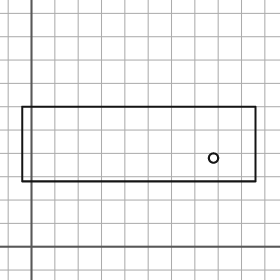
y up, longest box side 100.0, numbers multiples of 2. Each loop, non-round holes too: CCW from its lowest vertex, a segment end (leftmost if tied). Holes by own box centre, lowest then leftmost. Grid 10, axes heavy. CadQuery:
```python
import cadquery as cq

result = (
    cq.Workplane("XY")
    .moveTo(-4.0, 28.0)
    .lineTo(96.0, 28.0)
    .lineTo(96.0, 60.0)
    .lineTo(-4.0, 60.0)
    .close()
    .moveTo(78.0, 38.0)
    .circle(2.0)
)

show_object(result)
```